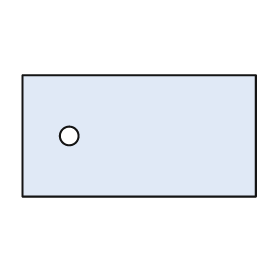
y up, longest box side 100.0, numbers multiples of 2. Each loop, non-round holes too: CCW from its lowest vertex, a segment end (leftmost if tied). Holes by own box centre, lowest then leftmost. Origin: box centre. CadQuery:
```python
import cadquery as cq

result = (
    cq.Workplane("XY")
    .moveTo(-50.0, -26.0)
    .lineTo(50.0, -26.0)
    .lineTo(50.0, 26.0)
    .lineTo(-50.0, 26.0)
    .close()
    .moveTo(-30.0, 0.0)
    .circle(4.0)
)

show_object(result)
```